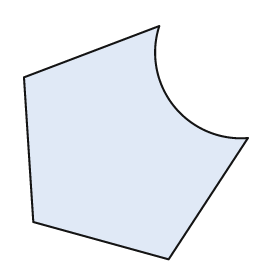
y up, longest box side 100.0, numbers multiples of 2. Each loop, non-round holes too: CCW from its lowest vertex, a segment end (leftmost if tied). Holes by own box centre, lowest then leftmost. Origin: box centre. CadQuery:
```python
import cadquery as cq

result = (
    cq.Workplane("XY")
    .moveTo(14.0, -50.0)
    .lineTo(48.0, 2.0)
    .threePointArc((16.0, 16.0), (10.0, 50.0))
    .lineTo(-48.0, 28.0)
    .lineTo(-44.0, -34.0)
    .close()
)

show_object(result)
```